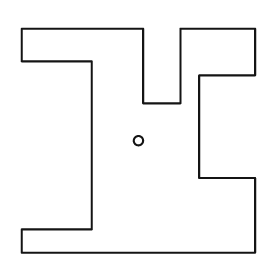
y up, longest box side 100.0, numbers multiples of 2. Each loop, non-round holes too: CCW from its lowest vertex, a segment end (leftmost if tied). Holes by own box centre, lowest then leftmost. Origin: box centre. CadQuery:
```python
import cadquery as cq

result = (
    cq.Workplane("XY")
    .moveTo(-50.0, -48.0)
    .lineTo(50.0, -48.0)
    .lineTo(50.0, -16.0)
    .lineTo(26.0, -16.0)
    .lineTo(26.0, 28.0)
    .lineTo(50.0, 28.0)
    .lineTo(50.0, 48.0)
    .lineTo(18.0, 48.0)
    .lineTo(18.0, 16.0)
    .lineTo(2.0, 16.0)
    .lineTo(2.0, 48.0)
    .lineTo(-50.0, 48.0)
    .lineTo(-50.0, 34.0)
    .lineTo(-20.0, 34.0)
    .lineTo(-20.0, -38.0)
    .lineTo(-50.0, -38.0)
    .close()
    .moveTo(0.0, 0.0)
    .circle(2.0)
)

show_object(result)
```